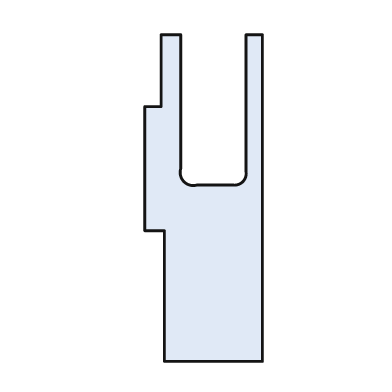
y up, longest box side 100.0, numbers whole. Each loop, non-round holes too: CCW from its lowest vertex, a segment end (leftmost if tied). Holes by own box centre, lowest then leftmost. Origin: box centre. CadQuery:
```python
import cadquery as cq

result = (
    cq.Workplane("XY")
    .moveTo(-12.0, -50.0)
    .lineTo(18.0, -50.0)
    .lineTo(18.0, 50.0)
    .lineTo(13.0, 50.0)
    .lineTo(13.0, 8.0)
    .threePointArc((12.0, 5.0), (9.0, 4.0))
    .lineTo(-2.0, 4.0)
    .threePointArc((-6.0, 5.0), (-7.0, 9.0))
    .lineTo(-7.0, 50.0)
    .lineTo(-13.0, 50.0)
    .lineTo(-13.0, 28.0)
    .lineTo(-18.0, 28.0)
    .lineTo(-18.0, -10.0)
    .lineTo(-12.0, -10.0)
    .close()
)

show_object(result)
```